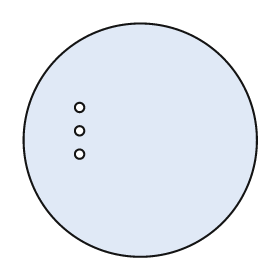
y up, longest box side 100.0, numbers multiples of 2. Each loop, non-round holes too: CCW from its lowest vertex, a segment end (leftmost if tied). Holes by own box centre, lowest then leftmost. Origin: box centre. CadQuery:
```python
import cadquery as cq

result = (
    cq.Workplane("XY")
    .moveTo(0.0, 0.0)
    .circle(50.0)
    .moveTo(-26.0, -6.0)
    .circle(2.0)
    .moveTo(-26.0, 4.0)
    .circle(2.0)
    .moveTo(-26.0, 14.0)
    .circle(2.0)
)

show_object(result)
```